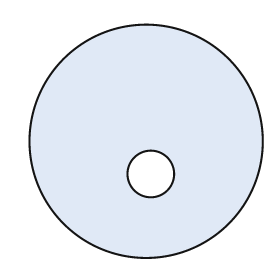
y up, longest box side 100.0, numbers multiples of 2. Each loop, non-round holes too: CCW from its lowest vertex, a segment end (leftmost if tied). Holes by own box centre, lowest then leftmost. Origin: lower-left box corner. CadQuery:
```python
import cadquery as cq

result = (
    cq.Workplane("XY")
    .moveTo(50.0, 50.0)
    .circle(50.0)
    .moveTo(52.0, 36.0)
    .circle(10.0)
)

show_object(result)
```